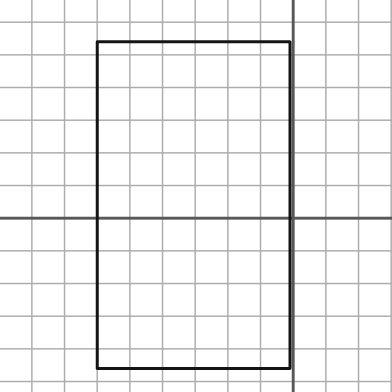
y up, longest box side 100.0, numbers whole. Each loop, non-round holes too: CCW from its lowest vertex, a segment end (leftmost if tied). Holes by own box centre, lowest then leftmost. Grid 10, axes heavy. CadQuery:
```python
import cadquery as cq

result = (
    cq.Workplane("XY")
    .moveTo(-60.0, -46.0)
    .lineTo(-1.0, -46.0)
    .lineTo(-1.0, 54.0)
    .lineTo(-60.0, 54.0)
    .close()
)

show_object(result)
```